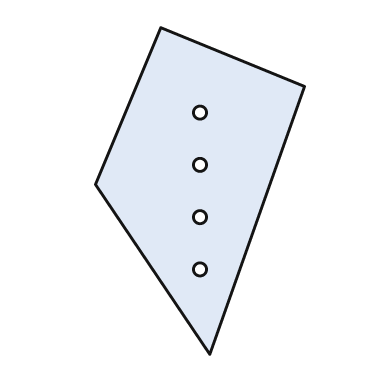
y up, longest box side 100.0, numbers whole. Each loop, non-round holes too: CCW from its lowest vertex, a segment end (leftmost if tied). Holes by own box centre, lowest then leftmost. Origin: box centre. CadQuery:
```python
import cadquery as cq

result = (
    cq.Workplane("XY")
    .moveTo(3.0, -50.0)
    .lineTo(32.0, 32.0)
    .lineTo(-12.0, 50.0)
    .lineTo(-32.0, 2.0)
    .close()
    .moveTo(0.0, -24.0)
    .circle(2.0)
    .moveTo(0.0, -8.0)
    .circle(2.0)
    .moveTo(0.0, 8.0)
    .circle(2.0)
    .moveTo(0.0, 24.0)
    .circle(2.0)
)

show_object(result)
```